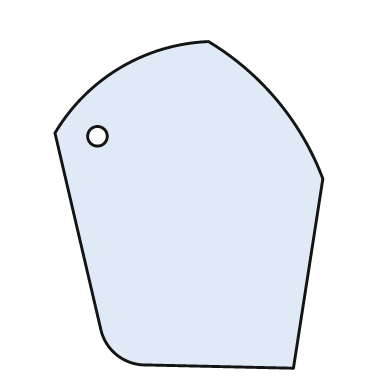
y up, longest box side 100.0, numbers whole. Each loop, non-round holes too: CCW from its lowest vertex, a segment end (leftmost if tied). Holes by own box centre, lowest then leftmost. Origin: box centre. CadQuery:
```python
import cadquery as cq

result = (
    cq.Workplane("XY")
    .moveTo(32.0, -50.0)
    .lineTo(41.0, 8.0)
    .threePointArc((27.0, 32.0), (6.0, 50.0))
    .threePointArc((-21.0, 42.0), (-41.0, 22.0))
    .lineTo(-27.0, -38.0)
    .threePointArc((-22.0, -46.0), (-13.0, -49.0))
    .close()
    .moveTo(-28.0, 21.0)
    .circle(3.0)
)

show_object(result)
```